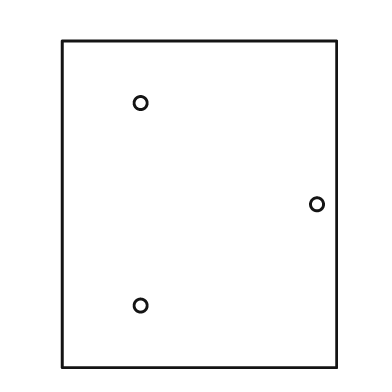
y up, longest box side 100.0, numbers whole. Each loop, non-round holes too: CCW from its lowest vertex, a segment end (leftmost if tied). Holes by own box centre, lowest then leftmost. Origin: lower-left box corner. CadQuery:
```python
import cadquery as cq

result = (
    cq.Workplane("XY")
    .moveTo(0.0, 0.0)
    .lineTo(84.0, 0.0)
    .lineTo(84.0, 100.0)
    .lineTo(0.0, 100.0)
    .close()
    .moveTo(24.0, 19.0)
    .circle(2.0)
    .moveTo(78.0, 50.0)
    .circle(2.0)
    .moveTo(24.0, 81.0)
    .circle(2.0)
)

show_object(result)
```